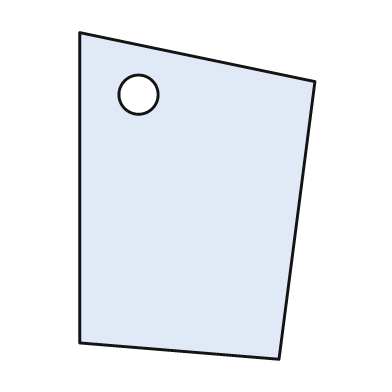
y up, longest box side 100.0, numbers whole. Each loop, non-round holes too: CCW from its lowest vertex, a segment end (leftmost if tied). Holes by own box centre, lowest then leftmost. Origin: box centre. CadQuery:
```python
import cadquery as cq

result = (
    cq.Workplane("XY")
    .moveTo(25.0, -50.0)
    .lineTo(36.0, 35.0)
    .lineTo(-36.0, 50.0)
    .lineTo(-36.0, -45.0)
    .close()
    .moveTo(-18.0, 31.0)
    .circle(6.0)
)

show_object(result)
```